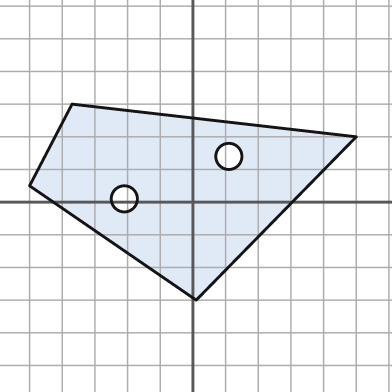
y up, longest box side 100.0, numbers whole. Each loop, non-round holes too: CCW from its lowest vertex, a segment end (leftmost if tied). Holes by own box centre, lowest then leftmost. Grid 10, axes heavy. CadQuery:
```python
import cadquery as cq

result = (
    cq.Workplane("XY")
    .moveTo(1.0, -30.0)
    .lineTo(50.0, 20.0)
    .lineTo(-37.0, 30.0)
    .lineTo(-50.0, 5.0)
    .close()
    .moveTo(-21.0, 1.0)
    .circle(4.0)
    .moveTo(11.0, 14.0)
    .circle(4.0)
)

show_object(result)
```